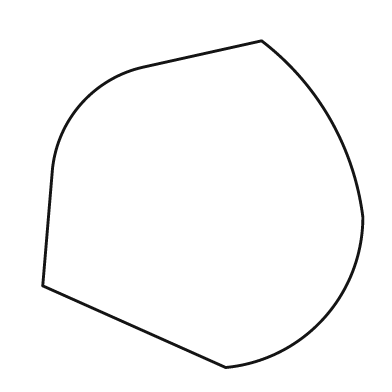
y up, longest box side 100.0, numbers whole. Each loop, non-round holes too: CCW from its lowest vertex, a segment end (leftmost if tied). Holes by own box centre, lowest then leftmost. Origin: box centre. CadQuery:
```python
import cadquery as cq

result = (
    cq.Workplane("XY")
    .moveTo(7.0, -50.0)
    .threePointArc((37.0, -35.0), (49.0, -4.0))
    .threePointArc((39.0, 26.0), (18.0, 50.0))
    .lineTo(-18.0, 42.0)
    .threePointArc((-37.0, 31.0), (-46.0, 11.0))
    .lineTo(-49.0, -25.0)
    .close()
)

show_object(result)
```